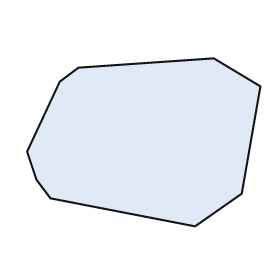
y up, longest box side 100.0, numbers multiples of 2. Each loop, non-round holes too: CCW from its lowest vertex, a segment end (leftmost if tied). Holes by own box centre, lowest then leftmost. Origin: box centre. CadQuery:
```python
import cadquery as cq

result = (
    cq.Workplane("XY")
    .moveTo(22.0, -36.0)
    .lineTo(42.0, -22.0)
    .lineTo(50.0, 24.0)
    .lineTo(30.0, 36.0)
    .lineTo(-28.0, 32.0)
    .lineTo(-36.0, 26.0)
    .lineTo(-50.0, -4.0)
    .lineTo(-46.0, -16.0)
    .lineTo(-40.0, -24.0)
    .close()
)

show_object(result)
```